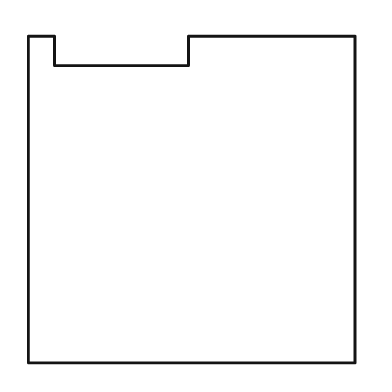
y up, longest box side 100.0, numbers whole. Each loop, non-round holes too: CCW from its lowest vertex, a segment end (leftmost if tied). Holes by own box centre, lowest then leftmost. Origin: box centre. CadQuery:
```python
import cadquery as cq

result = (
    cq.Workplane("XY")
    .moveTo(-50.0, -50.0)
    .lineTo(50.0, -50.0)
    .lineTo(50.0, 50.0)
    .lineTo(-1.0, 50.0)
    .lineTo(-1.0, 41.0)
    .lineTo(-42.0, 41.0)
    .lineTo(-42.0, 50.0)
    .lineTo(-50.0, 50.0)
    .close()
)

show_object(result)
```